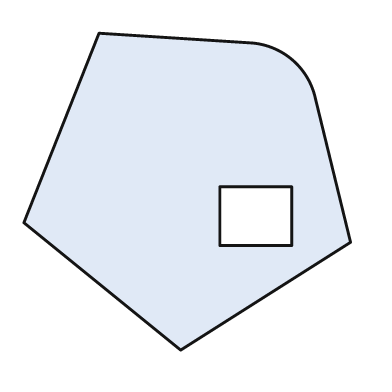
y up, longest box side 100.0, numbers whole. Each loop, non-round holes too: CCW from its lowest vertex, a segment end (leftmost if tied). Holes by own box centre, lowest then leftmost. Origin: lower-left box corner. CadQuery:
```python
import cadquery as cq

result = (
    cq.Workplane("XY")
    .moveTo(48.0, 0.0)
    .lineTo(100.0, 33.0)
    .lineTo(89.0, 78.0)
    .threePointArc((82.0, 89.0), (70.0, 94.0))
    .lineTo(23.0, 97.0)
    .lineTo(0.0, 39.0)
    .close()
    .moveTo(60.0, 32.0)
    .lineTo(82.0, 32.0)
    .lineTo(82.0, 50.0)
    .lineTo(60.0, 50.0)
    .close()
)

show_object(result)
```